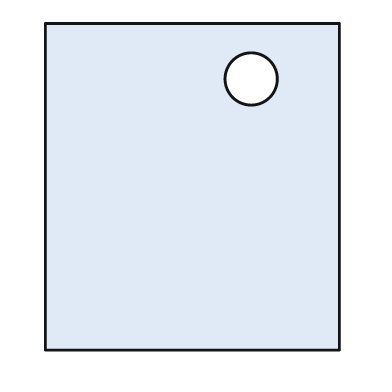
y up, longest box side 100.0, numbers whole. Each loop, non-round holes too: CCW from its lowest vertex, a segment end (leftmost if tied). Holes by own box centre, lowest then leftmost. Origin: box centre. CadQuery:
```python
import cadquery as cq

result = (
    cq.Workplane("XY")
    .moveTo(-45.0, -50.0)
    .lineTo(45.0, -50.0)
    .lineTo(45.0, 50.0)
    .lineTo(-45.0, 50.0)
    .close()
    .moveTo(18.0, 33.0)
    .circle(8.0)
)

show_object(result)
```